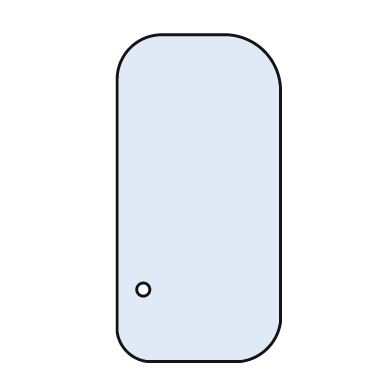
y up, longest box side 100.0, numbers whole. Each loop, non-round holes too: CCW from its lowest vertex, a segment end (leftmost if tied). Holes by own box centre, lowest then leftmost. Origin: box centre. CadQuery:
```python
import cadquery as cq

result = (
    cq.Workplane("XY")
    .moveTo(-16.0, -50.0)
    .lineTo(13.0, -50.0)
    .threePointArc((21.0, -46.0), (25.0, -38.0))
    .lineTo(25.0, 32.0)
    .threePointArc((20.0, 45.0), (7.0, 50.0))
    .lineTo(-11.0, 50.0)
    .threePointArc((-21.0, 46.0), (-25.0, 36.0))
    .lineTo(-25.0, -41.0)
    .threePointArc((-22.0, -47.0), (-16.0, -50.0))
    .close()
    .moveTo(-17.0, -28.0)
    .circle(2.0)
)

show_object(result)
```